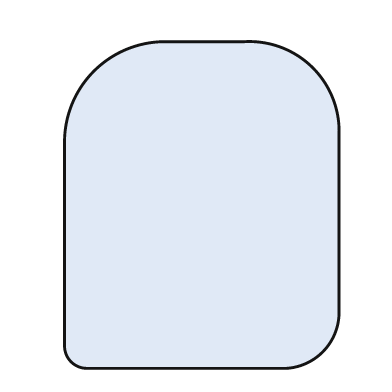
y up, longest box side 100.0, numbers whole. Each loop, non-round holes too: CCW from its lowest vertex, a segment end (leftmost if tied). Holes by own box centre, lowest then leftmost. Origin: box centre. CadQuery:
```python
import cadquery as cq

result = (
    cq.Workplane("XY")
    .moveTo(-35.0, -50.0)
    .lineTo(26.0, -50.0)
    .threePointArc((37.0, -45.0), (42.0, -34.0))
    .lineTo(42.0, 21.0)
    .threePointArc((34.0, 42.0), (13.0, 50.0))
    .lineTo(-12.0, 50.0)
    .threePointArc((-33.0, 41.0), (-42.0, 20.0))
    .lineTo(-42.0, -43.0)
    .threePointArc((-40.0, -48.0), (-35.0, -50.0))
    .close()
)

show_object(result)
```